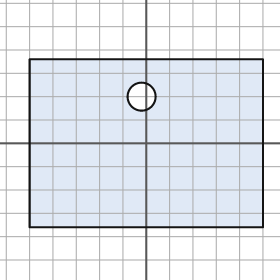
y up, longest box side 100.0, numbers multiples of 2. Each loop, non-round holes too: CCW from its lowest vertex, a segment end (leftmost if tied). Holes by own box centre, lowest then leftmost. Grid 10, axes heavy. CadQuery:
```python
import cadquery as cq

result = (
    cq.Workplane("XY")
    .moveTo(-50.0, -36.0)
    .lineTo(50.0, -36.0)
    .lineTo(50.0, 36.0)
    .lineTo(-50.0, 36.0)
    .close()
    .moveTo(-2.0, 20.0)
    .circle(6.0)
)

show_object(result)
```